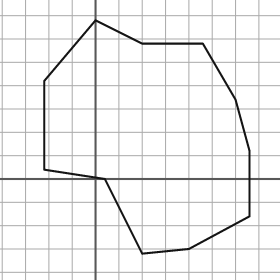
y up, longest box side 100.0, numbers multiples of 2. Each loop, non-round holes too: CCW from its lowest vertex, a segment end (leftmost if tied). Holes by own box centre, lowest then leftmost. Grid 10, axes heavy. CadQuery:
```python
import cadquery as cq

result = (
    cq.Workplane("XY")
    .moveTo(20.0, -32.0)
    .lineTo(40.0, -30.0)
    .lineTo(66.0, -16.0)
    .lineTo(66.0, 12.0)
    .lineTo(60.0, 34.0)
    .lineTo(46.0, 58.0)
    .lineTo(20.0, 58.0)
    .lineTo(0.0, 68.0)
    .lineTo(-22.0, 42.0)
    .lineTo(-22.0, 4.0)
    .lineTo(4.0, 0.0)
    .close()
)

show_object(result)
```